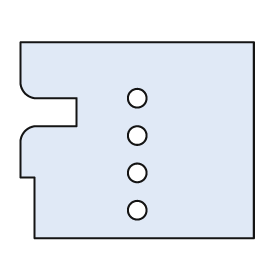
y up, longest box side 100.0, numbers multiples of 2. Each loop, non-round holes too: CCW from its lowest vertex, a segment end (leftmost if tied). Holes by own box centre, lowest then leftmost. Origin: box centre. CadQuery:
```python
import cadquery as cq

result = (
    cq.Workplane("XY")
    .moveTo(-44.0, -42.0)
    .lineTo(50.0, -42.0)
    .lineTo(50.0, 42.0)
    .lineTo(-50.0, 42.0)
    .lineTo(-50.0, 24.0)
    .threePointArc((-48.0, 20.0), (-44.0, 18.0))
    .lineTo(-26.0, 18.0)
    .lineTo(-26.0, 6.0)
    .lineTo(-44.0, 6.0)
    .threePointArc((-48.0, 4.0), (-50.0, 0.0))
    .lineTo(-50.0, -16.0)
    .lineTo(-44.0, -16.0)
    .close()
    .moveTo(0.0, -30.0)
    .circle(4.0)
    .moveTo(0.0, -14.0)
    .circle(4.0)
    .moveTo(0.0, 2.0)
    .circle(4.0)
    .moveTo(0.0, 18.0)
    .circle(4.0)
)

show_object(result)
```